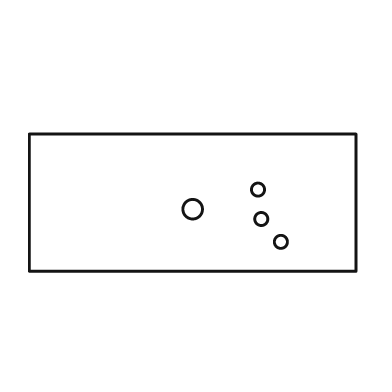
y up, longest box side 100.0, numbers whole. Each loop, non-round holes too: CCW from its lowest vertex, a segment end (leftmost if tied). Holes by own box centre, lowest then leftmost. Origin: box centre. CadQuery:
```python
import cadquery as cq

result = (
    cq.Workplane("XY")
    .moveTo(-50.0, -21.0)
    .lineTo(50.0, -21.0)
    .lineTo(50.0, 21.0)
    .lineTo(-50.0, 21.0)
    .close()
    .moveTo(27.0, -12.0)
    .circle(2.0)
    .moveTo(21.0, -5.0)
    .circle(2.0)
    .moveTo(0.0, -2.0)
    .circle(3.0)
    .moveTo(20.0, 4.0)
    .circle(2.0)
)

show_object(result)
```